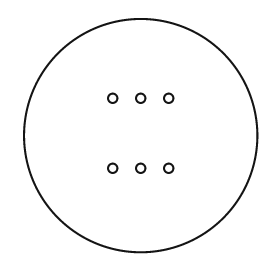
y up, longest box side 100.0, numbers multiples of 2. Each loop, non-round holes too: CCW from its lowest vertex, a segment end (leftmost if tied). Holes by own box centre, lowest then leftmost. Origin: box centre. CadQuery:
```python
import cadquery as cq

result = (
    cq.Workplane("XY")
    .moveTo(0.0, 0.0)
    .circle(50.0)
    .moveTo(-12.0, -14.0)
    .circle(2.0)
    .moveTo(0.0, -14.0)
    .circle(2.0)
    .moveTo(12.0, -14.0)
    .circle(2.0)
    .moveTo(-12.0, 16.0)
    .circle(2.0)
    .moveTo(0.0, 16.0)
    .circle(2.0)
    .moveTo(12.0, 16.0)
    .circle(2.0)
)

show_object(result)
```